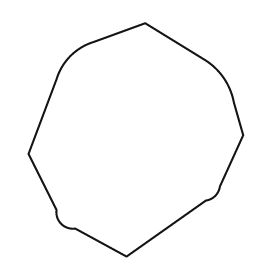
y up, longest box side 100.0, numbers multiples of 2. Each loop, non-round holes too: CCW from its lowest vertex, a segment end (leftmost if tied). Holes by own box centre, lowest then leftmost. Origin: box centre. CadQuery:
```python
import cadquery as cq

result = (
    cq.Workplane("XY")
    .moveTo(-4.0, -50.0)
    .lineTo(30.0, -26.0)
    .threePointArc((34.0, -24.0), (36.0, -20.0))
    .lineTo(46.0, 2.0)
    .lineTo(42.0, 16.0)
    .threePointArc((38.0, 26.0), (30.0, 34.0))
    .lineTo(4.0, 50.0)
    .lineTo(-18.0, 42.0)
    .threePointArc((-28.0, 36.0), (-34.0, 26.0))
    .lineTo(-46.0, -6.0)
    .lineTo(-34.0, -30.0)
    .threePointArc((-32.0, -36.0), (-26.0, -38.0))
    .close()
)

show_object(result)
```